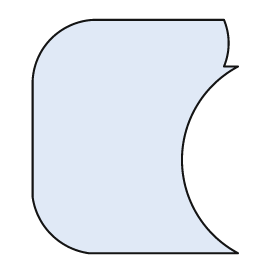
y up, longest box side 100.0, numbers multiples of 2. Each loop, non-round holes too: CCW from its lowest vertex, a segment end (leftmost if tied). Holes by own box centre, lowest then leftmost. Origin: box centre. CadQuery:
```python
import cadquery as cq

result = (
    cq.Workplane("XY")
    .moveTo(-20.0, -50.0)
    .lineTo(44.0, -50.0)
    .threePointArc((20.0, -10.0), (44.0, 30.0))
    .lineTo(38.0, 30.0)
    .threePointArc((40.0, 40.0), (38.0, 50.0))
    .lineTo(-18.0, 50.0)
    .threePointArc((-36.0, 42.0), (-44.0, 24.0))
    .lineTo(-44.0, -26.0)
    .threePointArc((-36.0, -42.0), (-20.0, -50.0))
    .close()
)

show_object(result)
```